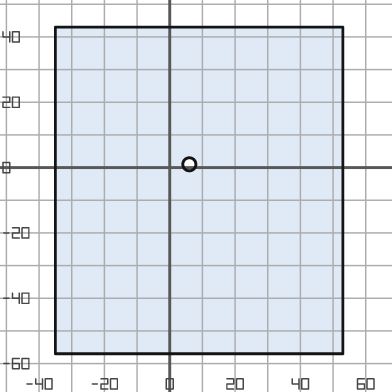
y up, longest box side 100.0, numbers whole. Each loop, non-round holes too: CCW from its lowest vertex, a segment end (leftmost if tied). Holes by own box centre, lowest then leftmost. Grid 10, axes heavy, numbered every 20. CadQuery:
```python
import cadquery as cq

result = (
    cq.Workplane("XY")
    .moveTo(-35.0, -57.0)
    .lineTo(53.0, -57.0)
    .lineTo(53.0, 43.0)
    .lineTo(-35.0, 43.0)
    .close()
    .moveTo(6.0, 1.0)
    .circle(2.0)
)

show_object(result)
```